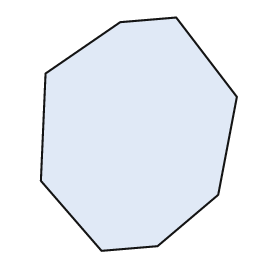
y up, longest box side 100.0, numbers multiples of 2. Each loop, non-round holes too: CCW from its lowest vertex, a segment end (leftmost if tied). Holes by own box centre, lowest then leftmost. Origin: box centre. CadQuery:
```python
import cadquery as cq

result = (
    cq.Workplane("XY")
    .moveTo(-16.0, -50.0)
    .lineTo(8.0, -48.0)
    .lineTo(34.0, -26.0)
    .lineTo(42.0, 16.0)
    .lineTo(16.0, 50.0)
    .lineTo(-8.0, 48.0)
    .lineTo(-40.0, 26.0)
    .lineTo(-42.0, -20.0)
    .close()
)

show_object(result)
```